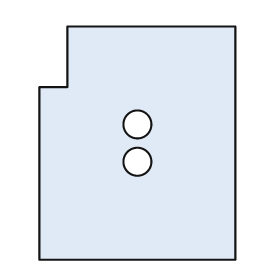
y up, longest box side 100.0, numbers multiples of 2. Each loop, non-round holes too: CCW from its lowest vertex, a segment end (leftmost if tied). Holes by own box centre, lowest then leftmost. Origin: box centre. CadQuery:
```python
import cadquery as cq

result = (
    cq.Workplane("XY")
    .moveTo(-42.0, -50.0)
    .lineTo(42.0, -50.0)
    .lineTo(42.0, 50.0)
    .lineTo(-30.0, 50.0)
    .lineTo(-30.0, 24.0)
    .lineTo(-42.0, 24.0)
    .close()
    .moveTo(0.0, -8.0)
    .circle(6.0)
    .moveTo(0.0, 8.0)
    .circle(6.0)
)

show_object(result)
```